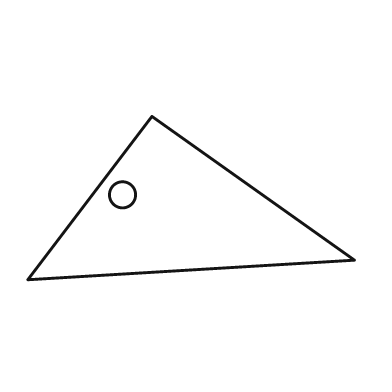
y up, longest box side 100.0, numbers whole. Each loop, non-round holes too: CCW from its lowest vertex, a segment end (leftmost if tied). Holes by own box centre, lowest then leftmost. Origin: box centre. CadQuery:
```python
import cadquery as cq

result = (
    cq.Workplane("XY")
    .moveTo(-50.0, -25.0)
    .lineTo(50.0, -19.0)
    .lineTo(-12.0, 25.0)
    .close()
    .moveTo(-21.0, 1.0)
    .circle(4.0)
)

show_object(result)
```